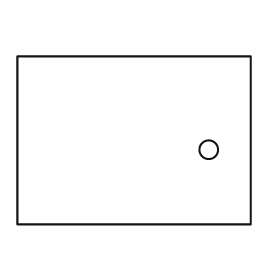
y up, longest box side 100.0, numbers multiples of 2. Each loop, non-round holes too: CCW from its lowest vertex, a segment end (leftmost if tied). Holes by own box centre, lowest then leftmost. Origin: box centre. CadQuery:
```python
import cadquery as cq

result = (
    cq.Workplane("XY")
    .moveTo(-50.0, -36.0)
    .lineTo(50.0, -36.0)
    .lineTo(50.0, 36.0)
    .lineTo(-50.0, 36.0)
    .close()
    .moveTo(32.0, -4.0)
    .circle(4.0)
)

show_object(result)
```